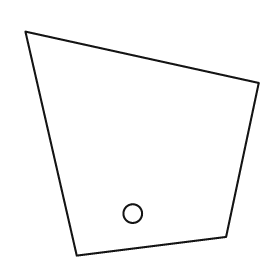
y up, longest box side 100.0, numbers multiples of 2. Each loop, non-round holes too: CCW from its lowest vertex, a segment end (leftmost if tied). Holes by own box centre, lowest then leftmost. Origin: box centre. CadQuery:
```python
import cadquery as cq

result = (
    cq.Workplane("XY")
    .moveTo(-28.0, -48.0)
    .lineTo(36.0, -40.0)
    .lineTo(50.0, 26.0)
    .lineTo(-50.0, 48.0)
    .close()
    .moveTo(-4.0, -30.0)
    .circle(4.0)
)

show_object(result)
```